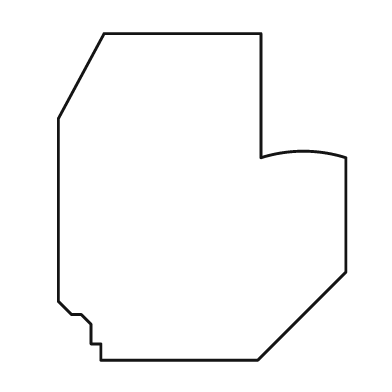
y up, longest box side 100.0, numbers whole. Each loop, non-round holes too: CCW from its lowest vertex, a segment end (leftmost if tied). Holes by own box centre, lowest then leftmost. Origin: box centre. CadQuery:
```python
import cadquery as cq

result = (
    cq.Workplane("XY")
    .moveTo(-31.0, -50.0)
    .lineTo(17.0, -50.0)
    .lineTo(44.0, -23.0)
    .lineTo(44.0, 12.0)
    .threePointArc((31.0, 14.0), (18.0, 12.0))
    .lineTo(18.0, 50.0)
    .lineTo(-30.0, 50.0)
    .lineTo(-44.0, 24.0)
    .lineTo(-44.0, -32.0)
    .lineTo(-40.0, -36.0)
    .lineTo(-37.0, -36.0)
    .lineTo(-34.0, -39.0)
    .lineTo(-34.0, -45.0)
    .lineTo(-31.0, -45.0)
    .close()
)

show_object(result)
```